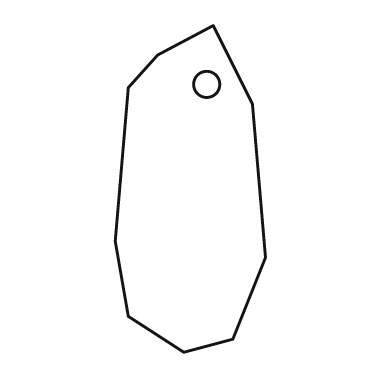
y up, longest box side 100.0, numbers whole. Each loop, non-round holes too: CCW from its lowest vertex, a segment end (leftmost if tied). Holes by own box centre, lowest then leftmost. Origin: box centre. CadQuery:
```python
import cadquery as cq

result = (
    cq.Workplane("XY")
    .moveTo(-2.0, -50.0)
    .lineTo(13.0, -46.0)
    .lineTo(23.0, -21.0)
    .lineTo(19.0, 26.0)
    .lineTo(7.0, 50.0)
    .lineTo(-10.0, 41.0)
    .lineTo(-19.0, 31.0)
    .lineTo(-23.0, -16.0)
    .lineTo(-19.0, -39.0)
    .close()
    .moveTo(5.0, 32.0)
    .circle(4.0)
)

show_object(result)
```